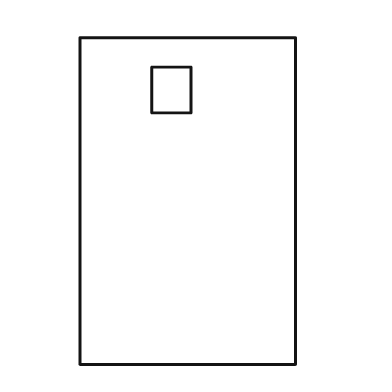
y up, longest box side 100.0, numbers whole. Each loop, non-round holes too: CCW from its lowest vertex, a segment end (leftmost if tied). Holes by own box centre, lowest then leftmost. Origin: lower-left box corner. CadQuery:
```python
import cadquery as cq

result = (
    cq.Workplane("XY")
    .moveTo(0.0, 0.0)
    .lineTo(66.0, 0.0)
    .lineTo(66.0, 100.0)
    .lineTo(0.0, 100.0)
    .close()
    .moveTo(22.0, 77.0)
    .lineTo(34.0, 77.0)
    .lineTo(34.0, 91.0)
    .lineTo(22.0, 91.0)
    .close()
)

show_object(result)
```